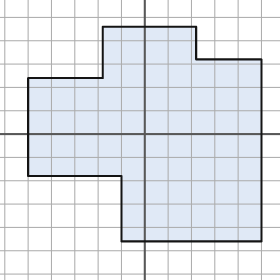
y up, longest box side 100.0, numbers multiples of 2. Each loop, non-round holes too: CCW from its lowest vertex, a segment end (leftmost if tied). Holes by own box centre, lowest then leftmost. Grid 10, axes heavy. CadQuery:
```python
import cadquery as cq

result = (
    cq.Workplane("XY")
    .moveTo(-10.0, -46.0)
    .lineTo(50.0, -46.0)
    .lineTo(50.0, 32.0)
    .lineTo(22.0, 32.0)
    .lineTo(22.0, 46.0)
    .lineTo(-18.0, 46.0)
    .lineTo(-18.0, 24.0)
    .lineTo(-50.0, 24.0)
    .lineTo(-50.0, -18.0)
    .lineTo(-10.0, -18.0)
    .close()
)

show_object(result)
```